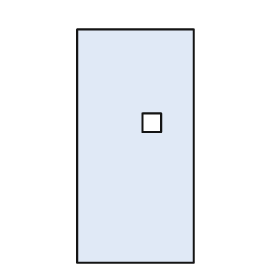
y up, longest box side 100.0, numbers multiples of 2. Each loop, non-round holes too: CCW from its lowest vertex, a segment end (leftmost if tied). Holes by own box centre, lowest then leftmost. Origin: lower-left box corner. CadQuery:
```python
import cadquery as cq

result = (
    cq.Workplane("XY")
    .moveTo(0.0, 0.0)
    .lineTo(50.0, 0.0)
    .lineTo(50.0, 100.0)
    .lineTo(0.0, 100.0)
    .close()
    .moveTo(28.0, 56.0)
    .lineTo(36.0, 56.0)
    .lineTo(36.0, 64.0)
    .lineTo(28.0, 64.0)
    .close()
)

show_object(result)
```